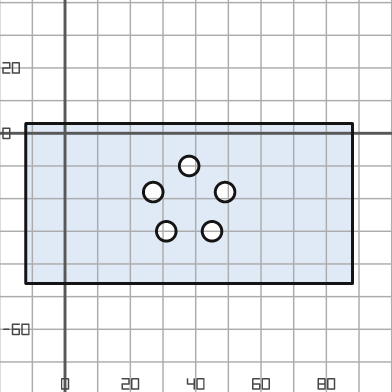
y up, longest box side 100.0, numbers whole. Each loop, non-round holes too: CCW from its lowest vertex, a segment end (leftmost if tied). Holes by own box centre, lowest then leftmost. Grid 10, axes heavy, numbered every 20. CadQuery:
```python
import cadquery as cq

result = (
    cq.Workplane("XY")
    .moveTo(-12.0, -46.0)
    .lineTo(88.0, -46.0)
    .lineTo(88.0, 3.0)
    .lineTo(-12.0, 3.0)
    .close()
    .moveTo(31.0, -30.0)
    .circle(3.0)
    .moveTo(45.0, -30.0)
    .circle(3.0)
    .moveTo(27.0, -18.0)
    .circle(3.0)
    .moveTo(49.0, -18.0)
    .circle(3.0)
    .moveTo(38.0, -10.0)
    .circle(3.0)
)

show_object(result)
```